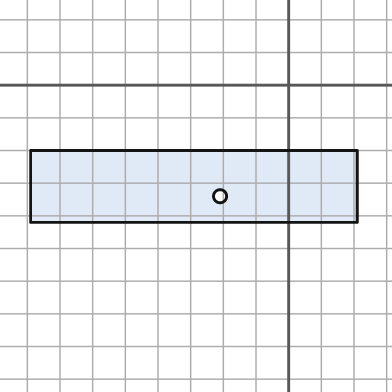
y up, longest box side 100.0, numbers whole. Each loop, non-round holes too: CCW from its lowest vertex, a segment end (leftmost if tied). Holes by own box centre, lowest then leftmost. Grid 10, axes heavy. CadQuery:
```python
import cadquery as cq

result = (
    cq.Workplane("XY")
    .moveTo(-79.0, -42.0)
    .lineTo(21.0, -42.0)
    .lineTo(21.0, -20.0)
    .lineTo(-79.0, -20.0)
    .close()
    .moveTo(-21.0, -34.0)
    .circle(2.0)
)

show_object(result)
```